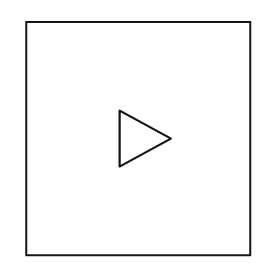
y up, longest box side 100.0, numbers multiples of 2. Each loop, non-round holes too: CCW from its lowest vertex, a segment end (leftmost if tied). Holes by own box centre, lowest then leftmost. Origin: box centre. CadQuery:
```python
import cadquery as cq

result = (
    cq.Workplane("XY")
    .moveTo(-48.0, -50.0)
    .lineTo(48.0, -50.0)
    .lineTo(48.0, 50.0)
    .lineTo(-48.0, 50.0)
    .close()
    .moveTo(-8.0, -12.0)
    .lineTo(14.0, 0.0)
    .lineTo(-8.0, 12.0)
    .close()
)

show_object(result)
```